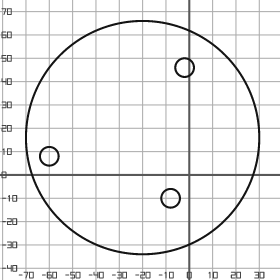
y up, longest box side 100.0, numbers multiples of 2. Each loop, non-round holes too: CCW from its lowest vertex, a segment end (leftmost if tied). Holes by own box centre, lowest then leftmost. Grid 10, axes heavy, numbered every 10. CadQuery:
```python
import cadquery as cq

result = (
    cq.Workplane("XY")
    .moveTo(-20.0, 16.0)
    .circle(50.0)
    .moveTo(-8.0, -10.0)
    .circle(4.0)
    .moveTo(-60.0, 8.0)
    .circle(4.0)
    .moveTo(-2.0, 46.0)
    .circle(4.0)
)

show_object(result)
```